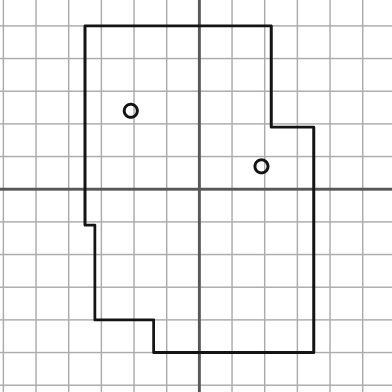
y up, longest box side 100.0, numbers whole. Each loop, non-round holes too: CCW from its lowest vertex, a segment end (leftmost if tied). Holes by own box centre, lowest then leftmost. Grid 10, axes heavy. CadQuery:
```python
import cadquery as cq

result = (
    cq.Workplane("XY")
    .moveTo(-14.0, -50.0)
    .lineTo(35.0, -50.0)
    .lineTo(35.0, 19.0)
    .lineTo(22.0, 19.0)
    .lineTo(22.0, 50.0)
    .lineTo(-35.0, 50.0)
    .lineTo(-35.0, -11.0)
    .lineTo(-32.0, -11.0)
    .lineTo(-32.0, -40.0)
    .lineTo(-14.0, -40.0)
    .close()
    .moveTo(19.0, 7.0)
    .circle(2.0)
    .moveTo(-21.0, 24.0)
    .circle(2.0)
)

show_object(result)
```